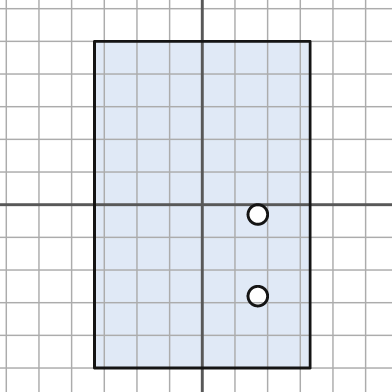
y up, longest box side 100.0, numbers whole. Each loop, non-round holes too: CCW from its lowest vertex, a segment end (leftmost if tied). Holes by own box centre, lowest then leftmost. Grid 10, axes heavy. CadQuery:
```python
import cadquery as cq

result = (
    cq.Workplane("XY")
    .moveTo(-33.0, -50.0)
    .lineTo(33.0, -50.0)
    .lineTo(33.0, 50.0)
    .lineTo(-33.0, 50.0)
    .close()
    .moveTo(17.0, -28.0)
    .circle(3.0)
    .moveTo(17.0, -3.0)
    .circle(3.0)
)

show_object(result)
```